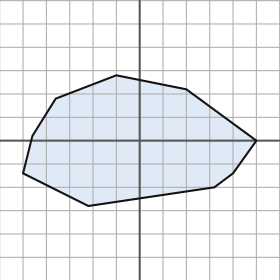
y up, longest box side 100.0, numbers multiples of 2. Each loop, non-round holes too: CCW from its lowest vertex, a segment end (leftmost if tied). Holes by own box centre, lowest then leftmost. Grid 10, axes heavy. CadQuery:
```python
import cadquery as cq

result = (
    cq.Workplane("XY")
    .moveTo(-22.0, -28.0)
    .lineTo(32.0, -20.0)
    .lineTo(40.0, -14.0)
    .lineTo(50.0, 0.0)
    .lineTo(20.0, 22.0)
    .lineTo(-10.0, 28.0)
    .lineTo(-36.0, 18.0)
    .lineTo(-46.0, 2.0)
    .lineTo(-50.0, -14.0)
    .close()
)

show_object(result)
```